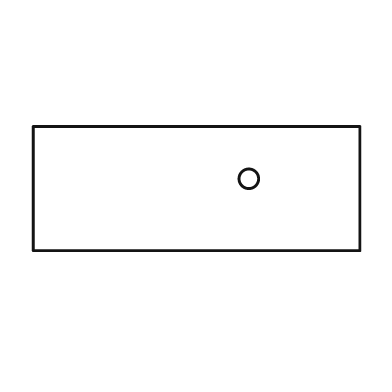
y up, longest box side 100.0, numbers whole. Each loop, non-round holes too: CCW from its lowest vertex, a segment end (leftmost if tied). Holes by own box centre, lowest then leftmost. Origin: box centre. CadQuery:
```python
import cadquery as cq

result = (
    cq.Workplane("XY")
    .moveTo(-50.0, -19.0)
    .lineTo(50.0, -19.0)
    .lineTo(50.0, 19.0)
    .lineTo(-50.0, 19.0)
    .close()
    .moveTo(16.0, 3.0)
    .circle(3.0)
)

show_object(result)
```